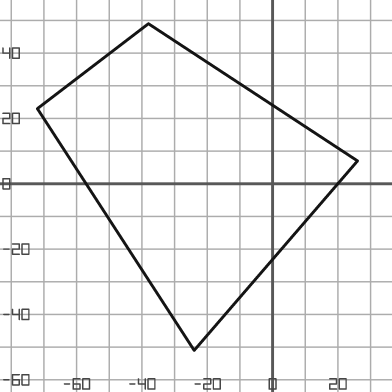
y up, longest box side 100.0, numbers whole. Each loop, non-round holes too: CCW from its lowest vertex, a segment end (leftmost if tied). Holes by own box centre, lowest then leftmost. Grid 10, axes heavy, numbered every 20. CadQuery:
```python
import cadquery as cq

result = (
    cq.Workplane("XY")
    .moveTo(-24.0, -51.0)
    .lineTo(26.0, 7.0)
    .lineTo(-38.0, 49.0)
    .lineTo(-72.0, 23.0)
    .close()
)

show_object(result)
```